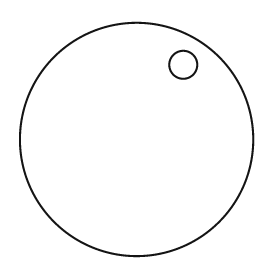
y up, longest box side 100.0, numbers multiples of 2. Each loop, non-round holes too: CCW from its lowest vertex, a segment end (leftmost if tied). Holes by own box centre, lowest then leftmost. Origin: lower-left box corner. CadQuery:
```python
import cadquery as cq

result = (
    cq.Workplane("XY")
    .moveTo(50.0, 50.0)
    .circle(50.0)
    .moveTo(70.0, 82.0)
    .circle(6.0)
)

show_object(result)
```